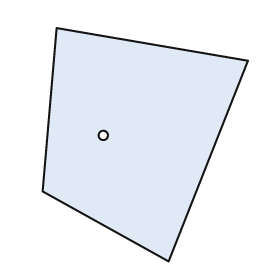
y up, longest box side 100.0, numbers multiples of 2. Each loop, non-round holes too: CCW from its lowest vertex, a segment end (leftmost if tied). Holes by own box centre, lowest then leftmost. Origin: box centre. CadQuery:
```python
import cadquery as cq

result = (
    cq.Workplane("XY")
    .moveTo(10.0, -50.0)
    .lineTo(44.0, 36.0)
    .lineTo(-38.0, 50.0)
    .lineTo(-44.0, -20.0)
    .close()
    .moveTo(-18.0, 4.0)
    .circle(2.0)
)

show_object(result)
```